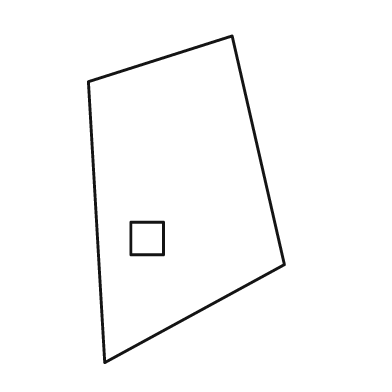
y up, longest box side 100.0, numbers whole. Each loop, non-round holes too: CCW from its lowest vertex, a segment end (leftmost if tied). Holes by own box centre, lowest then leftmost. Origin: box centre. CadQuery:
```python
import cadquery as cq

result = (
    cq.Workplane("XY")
    .moveTo(-25.0, -50.0)
    .lineTo(30.0, -20.0)
    .lineTo(14.0, 50.0)
    .lineTo(-30.0, 36.0)
    .close()
    .moveTo(-17.0, -17.0)
    .lineTo(-7.0, -17.0)
    .lineTo(-7.0, -7.0)
    .lineTo(-17.0, -7.0)
    .close()
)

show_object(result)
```